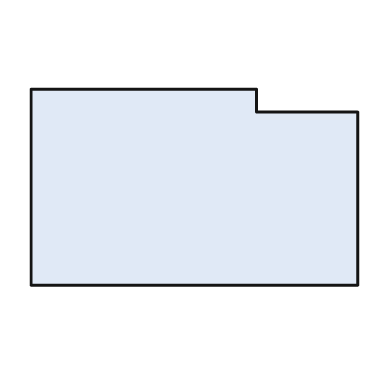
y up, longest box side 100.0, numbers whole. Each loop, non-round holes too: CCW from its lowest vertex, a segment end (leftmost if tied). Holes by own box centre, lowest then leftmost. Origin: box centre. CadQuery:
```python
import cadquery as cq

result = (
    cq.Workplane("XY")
    .moveTo(-50.0, -30.0)
    .lineTo(50.0, -30.0)
    .lineTo(50.0, 23.0)
    .lineTo(19.0, 23.0)
    .lineTo(19.0, 30.0)
    .lineTo(-50.0, 30.0)
    .close()
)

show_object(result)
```